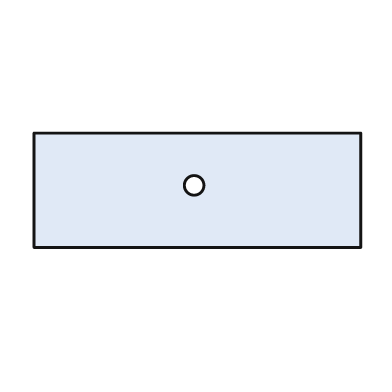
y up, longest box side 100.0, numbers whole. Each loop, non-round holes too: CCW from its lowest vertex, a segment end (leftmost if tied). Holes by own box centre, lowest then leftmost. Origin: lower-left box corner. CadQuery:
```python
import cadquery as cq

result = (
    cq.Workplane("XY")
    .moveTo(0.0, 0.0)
    .lineTo(100.0, 0.0)
    .lineTo(100.0, 35.0)
    .lineTo(0.0, 35.0)
    .close()
    .moveTo(49.0, 19.0)
    .circle(3.0)
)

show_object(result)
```